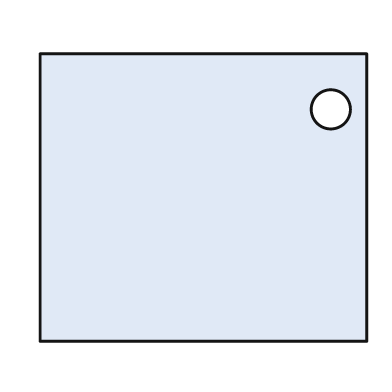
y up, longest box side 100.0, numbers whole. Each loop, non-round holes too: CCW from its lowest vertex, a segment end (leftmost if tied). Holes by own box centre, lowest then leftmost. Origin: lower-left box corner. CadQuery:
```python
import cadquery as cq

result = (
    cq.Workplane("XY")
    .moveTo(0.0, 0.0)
    .lineTo(100.0, 0.0)
    .lineTo(100.0, 88.0)
    .lineTo(0.0, 88.0)
    .close()
    .moveTo(89.0, 71.0)
    .circle(6.0)
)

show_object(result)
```